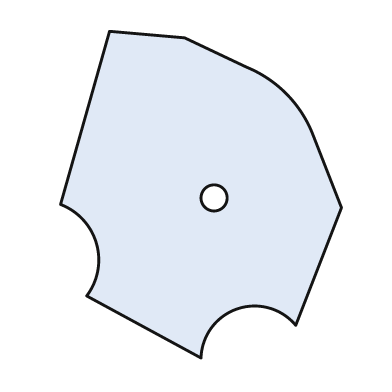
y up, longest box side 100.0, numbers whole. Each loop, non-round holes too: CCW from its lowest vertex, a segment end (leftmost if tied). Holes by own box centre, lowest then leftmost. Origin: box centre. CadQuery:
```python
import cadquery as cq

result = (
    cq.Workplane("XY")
    .moveTo(0.0, -50.0)
    .threePointArc((11.0, -35.0), (29.0, -40.0))
    .lineTo(43.0, -4.0)
    .lineTo(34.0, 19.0)
    .threePointArc((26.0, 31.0), (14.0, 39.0))
    .lineTo(-5.0, 48.0)
    .lineTo(-28.0, 50.0)
    .lineTo(-43.0, -3.0)
    .threePointArc((-32.0, -15.0), (-35.0, -31.0))
    .close()
    .moveTo(4.0, -1.0)
    .circle(4.0)
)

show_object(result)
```